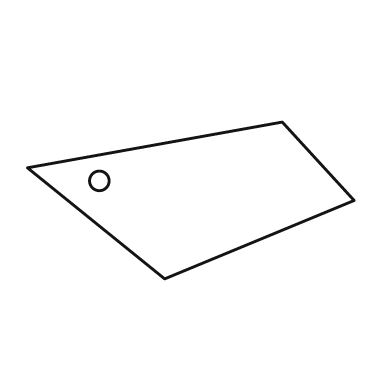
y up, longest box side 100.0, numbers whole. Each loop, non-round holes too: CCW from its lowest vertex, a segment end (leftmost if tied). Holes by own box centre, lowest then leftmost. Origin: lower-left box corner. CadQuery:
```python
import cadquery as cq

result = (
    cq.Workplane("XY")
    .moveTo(42.0, 0.0)
    .lineTo(100.0, 24.0)
    .lineTo(78.0, 48.0)
    .lineTo(0.0, 34.0)
    .close()
    .moveTo(22.0, 30.0)
    .circle(3.0)
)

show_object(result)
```